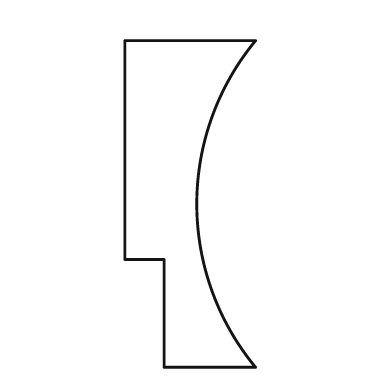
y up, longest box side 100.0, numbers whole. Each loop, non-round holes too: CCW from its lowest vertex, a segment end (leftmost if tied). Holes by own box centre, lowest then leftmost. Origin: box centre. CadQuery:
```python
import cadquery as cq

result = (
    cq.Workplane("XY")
    .moveTo(-8.0, -50.0)
    .lineTo(20.0, -50.0)
    .threePointArc((2.0, 0.0), (20.0, 50.0))
    .lineTo(-20.0, 50.0)
    .lineTo(-20.0, -17.0)
    .lineTo(-8.0, -17.0)
    .close()
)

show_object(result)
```